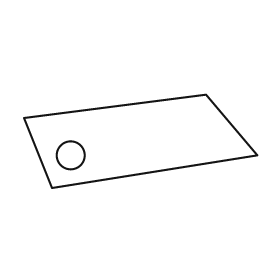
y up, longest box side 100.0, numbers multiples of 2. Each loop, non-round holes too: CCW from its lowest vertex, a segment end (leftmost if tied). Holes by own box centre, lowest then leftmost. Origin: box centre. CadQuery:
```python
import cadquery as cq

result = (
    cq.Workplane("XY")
    .moveTo(-38.0, -20.0)
    .lineTo(50.0, -6.0)
    .lineTo(28.0, 20.0)
    .lineTo(-50.0, 10.0)
    .close()
    .moveTo(-30.0, -6.0)
    .circle(6.0)
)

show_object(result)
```